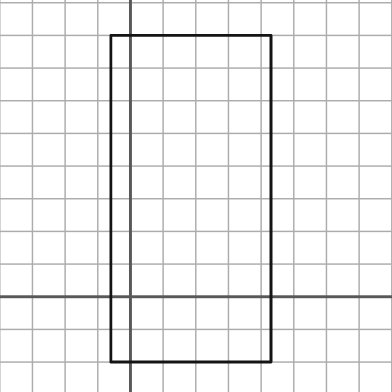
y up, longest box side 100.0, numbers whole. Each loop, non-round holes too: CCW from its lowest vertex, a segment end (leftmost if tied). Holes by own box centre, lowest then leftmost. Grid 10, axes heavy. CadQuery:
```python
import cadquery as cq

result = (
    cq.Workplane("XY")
    .moveTo(-6.0, -20.0)
    .lineTo(43.0, -20.0)
    .lineTo(43.0, 80.0)
    .lineTo(-6.0, 80.0)
    .close()
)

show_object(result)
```